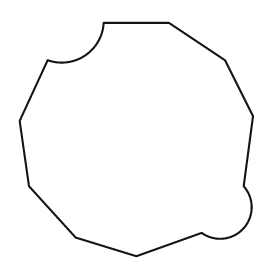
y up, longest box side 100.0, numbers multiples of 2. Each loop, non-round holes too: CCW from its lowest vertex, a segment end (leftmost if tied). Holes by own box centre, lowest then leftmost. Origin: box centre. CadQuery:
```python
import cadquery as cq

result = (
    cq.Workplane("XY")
    .moveTo(0.0, -50.0)
    .lineTo(28.0, -40.0)
    .threePointArc((46.0, -38.0), (46.0, -20.0))
    .lineTo(50.0, 10.0)
    .lineTo(38.0, 34.0)
    .lineTo(14.0, 50.0)
    .lineTo(-14.0, 50.0)
    .threePointArc((-22.0, 36.0), (-38.0, 34.0))
    .lineTo(-50.0, 8.0)
    .lineTo(-46.0, -20.0)
    .lineTo(-26.0, -42.0)
    .close()
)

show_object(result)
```